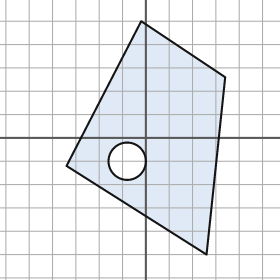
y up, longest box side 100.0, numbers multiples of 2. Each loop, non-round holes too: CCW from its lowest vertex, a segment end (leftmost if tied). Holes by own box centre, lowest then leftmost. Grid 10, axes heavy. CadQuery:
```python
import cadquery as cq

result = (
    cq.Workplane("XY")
    .moveTo(26.0, -50.0)
    .lineTo(34.0, 26.0)
    .lineTo(-2.0, 50.0)
    .lineTo(-34.0, -12.0)
    .close()
    .moveTo(-8.0, -10.0)
    .circle(8.0)
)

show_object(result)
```